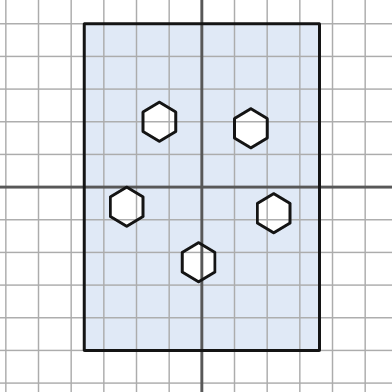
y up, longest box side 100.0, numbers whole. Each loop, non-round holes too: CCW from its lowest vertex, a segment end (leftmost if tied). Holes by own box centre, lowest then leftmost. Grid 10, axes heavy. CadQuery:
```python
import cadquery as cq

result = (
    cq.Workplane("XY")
    .moveTo(-36.0, -50.0)
    .lineTo(36.0, -50.0)
    .lineTo(36.0, 50.0)
    .lineTo(-36.0, 50.0)
    .close()
    .moveTo(-1.0, -29.0)
    .lineTo(4.0, -26.0)
    .lineTo(4.0, -20.0)
    .lineTo(-1.0, -17.0)
    .lineTo(-6.0, -20.0)
    .lineTo(-6.0, -26.0)
    .close()
    .moveTo(22.0, -14.0)
    .lineTo(27.0, -11.0)
    .lineTo(27.0, -5.0)
    .lineTo(22.0, -2.0)
    .lineTo(17.0, -5.0)
    .lineTo(17.0, -11.0)
    .close()
    .moveTo(-23.0, -12.0)
    .lineTo(-18.0, -9.0)
    .lineTo(-18.0, -3.0)
    .lineTo(-23.0, 0.0)
    .lineTo(-28.0, -3.0)
    .lineTo(-28.0, -9.0)
    .close()
    .moveTo(15.0, 12.0)
    .lineTo(20.0, 15.0)
    .lineTo(20.0, 21.0)
    .lineTo(15.0, 24.0)
    .lineTo(10.0, 21.0)
    .lineTo(10.0, 15.0)
    .close()
    .moveTo(-13.0, 14.0)
    .lineTo(-8.0, 17.0)
    .lineTo(-8.0, 23.0)
    .lineTo(-13.0, 26.0)
    .lineTo(-18.0, 23.0)
    .lineTo(-18.0, 17.0)
    .close()
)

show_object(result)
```